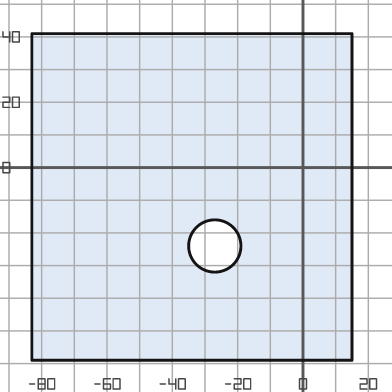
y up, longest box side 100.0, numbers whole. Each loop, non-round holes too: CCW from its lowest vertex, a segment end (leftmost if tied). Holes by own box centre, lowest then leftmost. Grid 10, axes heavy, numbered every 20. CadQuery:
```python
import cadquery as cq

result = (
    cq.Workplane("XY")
    .moveTo(-83.0, -59.0)
    .lineTo(15.0, -59.0)
    .lineTo(15.0, 41.0)
    .lineTo(-83.0, 41.0)
    .close()
    .moveTo(-27.0, -24.0)
    .circle(8.0)
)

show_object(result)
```